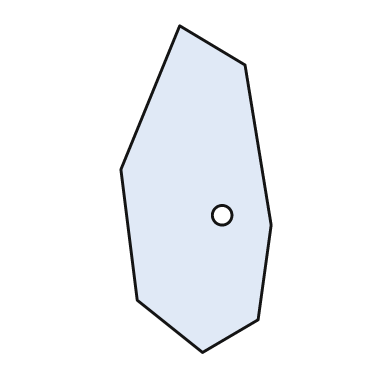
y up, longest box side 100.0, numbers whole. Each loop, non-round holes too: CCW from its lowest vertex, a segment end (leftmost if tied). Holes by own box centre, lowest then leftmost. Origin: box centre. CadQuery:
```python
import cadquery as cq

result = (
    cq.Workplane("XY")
    .moveTo(2.0, -50.0)
    .lineTo(19.0, -40.0)
    .lineTo(23.0, -11.0)
    .lineTo(15.0, 38.0)
    .lineTo(-5.0, 50.0)
    .lineTo(-23.0, 6.0)
    .lineTo(-18.0, -34.0)
    .close()
    .moveTo(8.0, -8.0)
    .circle(3.0)
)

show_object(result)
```